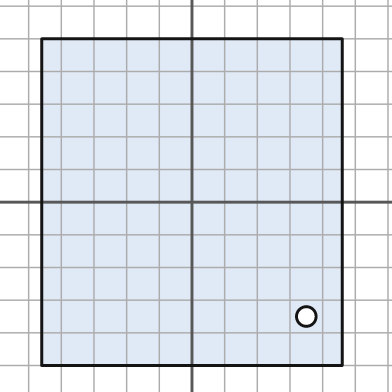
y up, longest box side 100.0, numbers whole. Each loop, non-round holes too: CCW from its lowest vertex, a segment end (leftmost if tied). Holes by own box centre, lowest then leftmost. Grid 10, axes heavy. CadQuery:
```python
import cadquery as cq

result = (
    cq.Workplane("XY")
    .moveTo(-46.0, -50.0)
    .lineTo(46.0, -50.0)
    .lineTo(46.0, 50.0)
    .lineTo(-46.0, 50.0)
    .close()
    .moveTo(35.0, -35.0)
    .circle(3.0)
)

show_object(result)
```